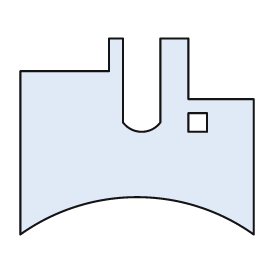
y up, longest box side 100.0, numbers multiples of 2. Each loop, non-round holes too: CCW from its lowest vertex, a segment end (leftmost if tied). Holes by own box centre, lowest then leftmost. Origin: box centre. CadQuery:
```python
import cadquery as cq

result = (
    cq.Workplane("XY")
    .moveTo(-50.0, -42.0)
    .threePointArc((0.0, -26.0), (50.0, -42.0))
    .lineTo(50.0, 16.0)
    .lineTo(22.0, 16.0)
    .lineTo(22.0, 42.0)
    .lineTo(10.0, 42.0)
    .lineTo(10.0, 6.0)
    .threePointArc((2.0, 2.0), (-6.0, 6.0))
    .lineTo(-6.0, 42.0)
    .lineTo(-12.0, 42.0)
    .lineTo(-12.0, 28.0)
    .lineTo(-50.0, 28.0)
    .close()
    .moveTo(22.0, 2.0)
    .lineTo(30.0, 2.0)
    .lineTo(30.0, 10.0)
    .lineTo(22.0, 10.0)
    .close()
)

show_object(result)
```